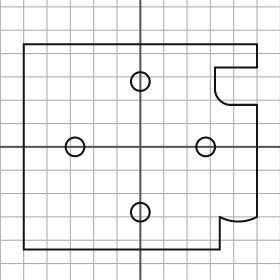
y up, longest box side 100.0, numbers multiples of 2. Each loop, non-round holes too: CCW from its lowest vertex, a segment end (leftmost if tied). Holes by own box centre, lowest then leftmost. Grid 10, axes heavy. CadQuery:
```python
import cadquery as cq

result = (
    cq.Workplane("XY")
    .moveTo(-50.0, -44.0)
    .lineTo(34.0, -44.0)
    .lineTo(34.0, -30.0)
    .threePointArc((42.0, -32.0), (50.0, -30.0))
    .lineTo(50.0, 18.0)
    .lineTo(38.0, 18.0)
    .threePointArc((34.0, 20.0), (32.0, 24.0))
    .lineTo(32.0, 34.0)
    .lineTo(50.0, 34.0)
    .lineTo(50.0, 44.0)
    .lineTo(-50.0, 44.0)
    .close()
    .moveTo(0.0, -28.0)
    .circle(4.0)
    .moveTo(-28.0, 0.0)
    .circle(4.0)
    .moveTo(28.0, 0.0)
    .circle(4.0)
    .moveTo(0.0, 28.0)
    .circle(4.0)
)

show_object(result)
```